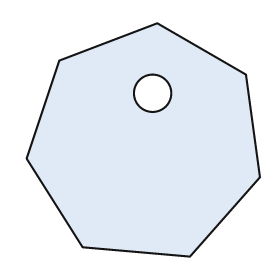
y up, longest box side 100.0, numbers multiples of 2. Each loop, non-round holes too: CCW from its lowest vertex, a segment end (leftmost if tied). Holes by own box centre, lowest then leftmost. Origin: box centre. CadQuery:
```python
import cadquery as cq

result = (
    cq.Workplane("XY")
    .moveTo(20.0, -50.0)
    .lineTo(50.0, -16.0)
    .lineTo(44.0, 28.0)
    .lineTo(6.0, 50.0)
    .lineTo(-36.0, 34.0)
    .lineTo(-50.0, -8.0)
    .lineTo(-26.0, -46.0)
    .close()
    .moveTo(4.0, 20.0)
    .circle(8.0)
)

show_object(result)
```